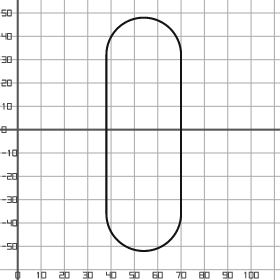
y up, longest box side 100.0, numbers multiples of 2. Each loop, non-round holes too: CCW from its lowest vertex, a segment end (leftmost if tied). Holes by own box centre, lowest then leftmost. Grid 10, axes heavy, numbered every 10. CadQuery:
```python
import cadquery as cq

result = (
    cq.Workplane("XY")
    .moveTo(38.0, -36.0)
    .threePointArc((54.0, -52.0), (70.0, -36.0))
    .lineTo(70.0, 32.0)
    .threePointArc((54.0, 48.0), (38.0, 32.0))
    .close()
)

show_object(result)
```